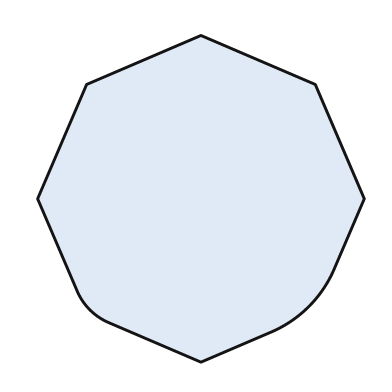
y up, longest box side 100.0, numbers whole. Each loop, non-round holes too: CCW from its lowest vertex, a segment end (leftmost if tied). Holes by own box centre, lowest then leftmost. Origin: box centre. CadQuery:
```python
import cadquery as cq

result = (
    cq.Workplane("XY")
    .moveTo(0.0, -50.0)
    .lineTo(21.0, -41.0)
    .threePointArc((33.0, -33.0), (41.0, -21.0))
    .lineTo(50.0, 0.0)
    .lineTo(35.0, 35.0)
    .lineTo(0.0, 50.0)
    .lineTo(-35.0, 35.0)
    .lineTo(-50.0, 0.0)
    .lineTo(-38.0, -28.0)
    .threePointArc((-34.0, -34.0), (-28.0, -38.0))
    .close()
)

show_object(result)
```